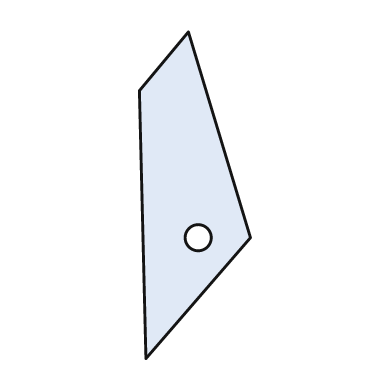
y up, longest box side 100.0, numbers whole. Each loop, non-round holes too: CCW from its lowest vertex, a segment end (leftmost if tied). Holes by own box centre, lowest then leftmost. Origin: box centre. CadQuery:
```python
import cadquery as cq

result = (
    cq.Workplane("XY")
    .moveTo(-15.0, -50.0)
    .lineTo(17.0, -13.0)
    .lineTo(-2.0, 50.0)
    .lineTo(-17.0, 32.0)
    .close()
    .moveTo(1.0, -13.0)
    .circle(4.0)
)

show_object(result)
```